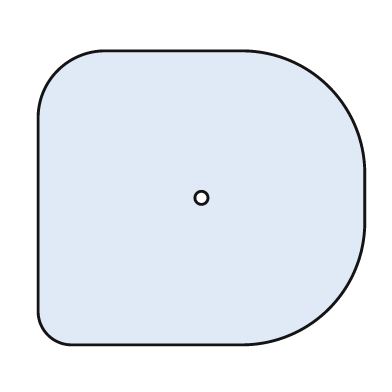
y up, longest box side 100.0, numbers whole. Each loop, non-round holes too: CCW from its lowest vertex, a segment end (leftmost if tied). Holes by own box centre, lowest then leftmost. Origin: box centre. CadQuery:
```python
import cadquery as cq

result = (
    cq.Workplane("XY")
    .moveTo(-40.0, -45.0)
    .lineTo(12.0, -45.0)
    .threePointArc((39.0, -34.0), (50.0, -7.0))
    .lineTo(50.0, 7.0)
    .threePointArc((39.0, 34.0), (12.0, 45.0))
    .lineTo(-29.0, 45.0)
    .threePointArc((-44.0, 39.0), (-50.0, 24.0))
    .lineTo(-50.0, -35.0)
    .threePointArc((-47.0, -42.0), (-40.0, -45.0))
    .close()
    .moveTo(0.0, 0.0)
    .circle(2.0)
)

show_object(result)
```